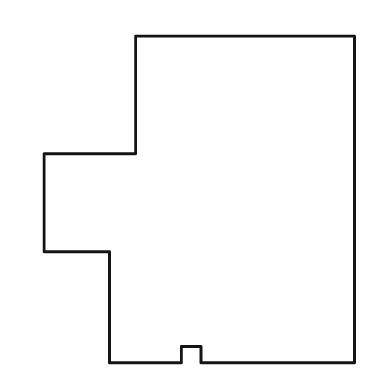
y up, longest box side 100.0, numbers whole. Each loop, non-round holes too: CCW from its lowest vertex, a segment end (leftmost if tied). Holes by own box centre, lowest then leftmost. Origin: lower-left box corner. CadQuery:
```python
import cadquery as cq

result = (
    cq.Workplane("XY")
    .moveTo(20.0, 0.0)
    .lineTo(42.0, 0.0)
    .lineTo(42.0, 5.0)
    .lineTo(48.0, 5.0)
    .lineTo(48.0, 0.0)
    .lineTo(95.0, 0.0)
    .lineTo(95.0, 100.0)
    .lineTo(28.0, 100.0)
    .lineTo(28.0, 64.0)
    .lineTo(0.0, 64.0)
    .lineTo(0.0, 34.0)
    .lineTo(20.0, 34.0)
    .close()
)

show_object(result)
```